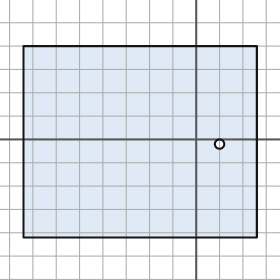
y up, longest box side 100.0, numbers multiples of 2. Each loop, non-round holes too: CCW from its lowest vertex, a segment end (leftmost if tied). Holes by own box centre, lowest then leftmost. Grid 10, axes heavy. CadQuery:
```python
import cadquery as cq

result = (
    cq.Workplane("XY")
    .moveTo(-74.0, -42.0)
    .lineTo(26.0, -42.0)
    .lineTo(26.0, 40.0)
    .lineTo(-74.0, 40.0)
    .close()
    .moveTo(10.0, -2.0)
    .circle(2.0)
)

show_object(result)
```